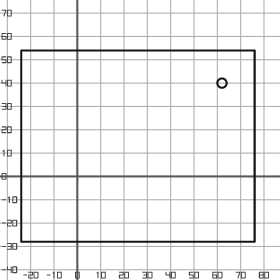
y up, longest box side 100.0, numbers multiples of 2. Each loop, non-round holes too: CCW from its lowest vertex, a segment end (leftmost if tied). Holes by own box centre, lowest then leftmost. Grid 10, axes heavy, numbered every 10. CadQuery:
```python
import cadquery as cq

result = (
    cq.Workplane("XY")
    .moveTo(-24.0, -28.0)
    .lineTo(76.0, -28.0)
    .lineTo(76.0, 54.0)
    .lineTo(-24.0, 54.0)
    .close()
    .moveTo(62.0, 40.0)
    .circle(2.0)
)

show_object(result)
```